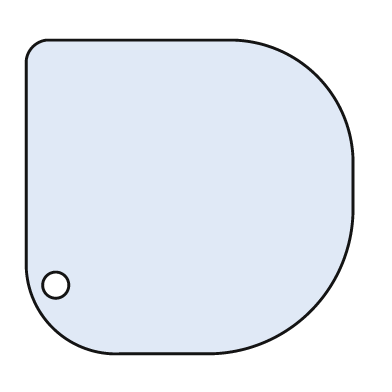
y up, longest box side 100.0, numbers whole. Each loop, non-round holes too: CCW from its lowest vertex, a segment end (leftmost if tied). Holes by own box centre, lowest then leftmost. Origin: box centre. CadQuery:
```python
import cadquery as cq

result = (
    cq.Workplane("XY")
    .moveTo(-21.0, -48.0)
    .lineTo(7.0, -48.0)
    .threePointArc((37.0, -35.0), (50.0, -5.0))
    .lineTo(50.0, 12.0)
    .threePointArc((39.0, 37.0), (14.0, 48.0))
    .lineTo(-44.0, 48.0)
    .threePointArc((-48.0, 46.0), (-50.0, 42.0))
    .lineTo(-50.0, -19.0)
    .threePointArc((-42.0, -40.0), (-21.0, -48.0))
    .close()
    .moveTo(-41.0, -27.0)
    .circle(4.0)
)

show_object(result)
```